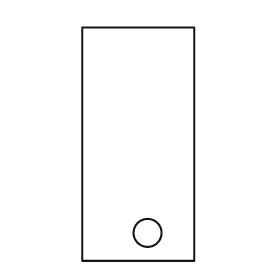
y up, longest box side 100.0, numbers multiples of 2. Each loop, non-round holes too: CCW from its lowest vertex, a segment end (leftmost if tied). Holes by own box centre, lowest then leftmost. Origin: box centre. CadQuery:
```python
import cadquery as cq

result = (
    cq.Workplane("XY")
    .moveTo(-24.0, -50.0)
    .lineTo(24.0, -50.0)
    .lineTo(24.0, 50.0)
    .lineTo(-24.0, 50.0)
    .close()
    .moveTo(4.0, -38.0)
    .circle(6.0)
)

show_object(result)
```